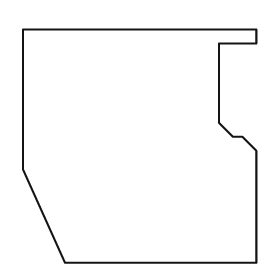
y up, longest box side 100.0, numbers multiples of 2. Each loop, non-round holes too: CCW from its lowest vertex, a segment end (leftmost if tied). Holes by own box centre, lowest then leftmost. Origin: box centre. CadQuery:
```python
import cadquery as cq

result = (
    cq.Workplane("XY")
    .moveTo(-32.0, -50.0)
    .lineTo(50.0, -50.0)
    .lineTo(50.0, -2.0)
    .lineTo(44.0, 4.0)
    .lineTo(40.0, 4.0)
    .lineTo(34.0, 10.0)
    .lineTo(34.0, 44.0)
    .lineTo(50.0, 44.0)
    .lineTo(50.0, 50.0)
    .lineTo(-50.0, 50.0)
    .lineTo(-50.0, -10.0)
    .close()
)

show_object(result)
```